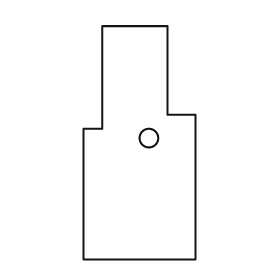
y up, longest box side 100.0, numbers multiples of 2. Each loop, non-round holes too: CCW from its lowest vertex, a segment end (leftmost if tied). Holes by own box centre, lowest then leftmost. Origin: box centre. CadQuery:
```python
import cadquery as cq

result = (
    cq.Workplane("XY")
    .moveTo(-24.0, -50.0)
    .lineTo(24.0, -50.0)
    .lineTo(24.0, 12.0)
    .lineTo(12.0, 12.0)
    .lineTo(12.0, 50.0)
    .lineTo(-16.0, 50.0)
    .lineTo(-16.0, 6.0)
    .lineTo(-24.0, 6.0)
    .close()
    .moveTo(4.0, 2.0)
    .circle(4.0)
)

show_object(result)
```